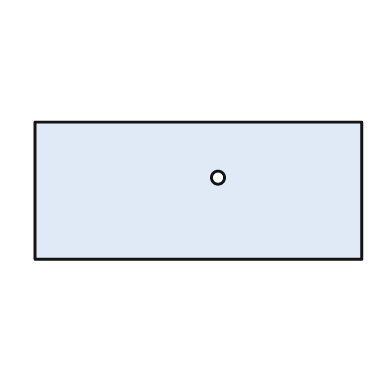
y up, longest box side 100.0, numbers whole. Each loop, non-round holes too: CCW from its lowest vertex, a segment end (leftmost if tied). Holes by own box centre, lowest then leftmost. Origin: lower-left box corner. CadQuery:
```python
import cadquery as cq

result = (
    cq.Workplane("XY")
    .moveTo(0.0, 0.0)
    .lineTo(100.0, 0.0)
    .lineTo(100.0, 42.0)
    .lineTo(0.0, 42.0)
    .close()
    .moveTo(56.0, 25.0)
    .circle(2.0)
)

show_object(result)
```